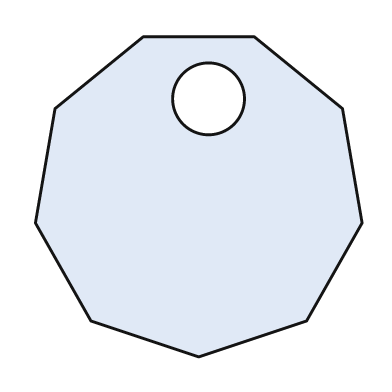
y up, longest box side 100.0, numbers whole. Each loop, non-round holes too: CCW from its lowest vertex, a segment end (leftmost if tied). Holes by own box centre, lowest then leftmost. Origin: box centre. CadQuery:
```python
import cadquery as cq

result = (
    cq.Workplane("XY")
    .moveTo(0.0, -49.0)
    .lineTo(33.0, -38.0)
    .lineTo(50.0, -8.0)
    .lineTo(44.0, 27.0)
    .lineTo(17.0, 49.0)
    .lineTo(-17.0, 49.0)
    .lineTo(-44.0, 27.0)
    .lineTo(-50.0, -8.0)
    .lineTo(-33.0, -38.0)
    .close()
    .moveTo(3.0, 30.0)
    .circle(11.0)
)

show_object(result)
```